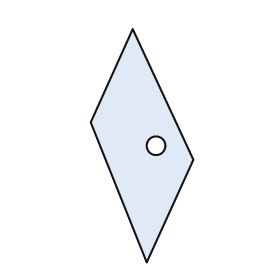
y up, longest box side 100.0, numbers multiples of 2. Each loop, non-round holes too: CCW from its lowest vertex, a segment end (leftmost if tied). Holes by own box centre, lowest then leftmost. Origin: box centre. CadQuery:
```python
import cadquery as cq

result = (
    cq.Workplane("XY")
    .moveTo(2.0, -50.0)
    .lineTo(22.0, -6.0)
    .lineTo(-4.0, 50.0)
    .lineTo(-22.0, 10.0)
    .close()
    .moveTo(6.0, 0.0)
    .circle(4.0)
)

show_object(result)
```